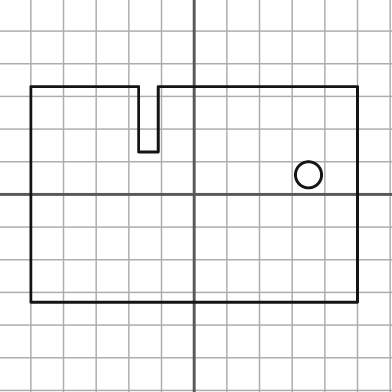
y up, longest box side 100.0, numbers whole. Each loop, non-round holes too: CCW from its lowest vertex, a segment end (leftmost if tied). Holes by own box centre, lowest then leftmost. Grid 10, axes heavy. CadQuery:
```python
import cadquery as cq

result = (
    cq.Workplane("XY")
    .moveTo(-50.0, -33.0)
    .lineTo(50.0, -33.0)
    .lineTo(50.0, 33.0)
    .lineTo(-11.0, 33.0)
    .lineTo(-11.0, 13.0)
    .lineTo(-17.0, 13.0)
    .lineTo(-17.0, 33.0)
    .lineTo(-50.0, 33.0)
    .close()
    .moveTo(35.0, 6.0)
    .circle(4.0)
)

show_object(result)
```